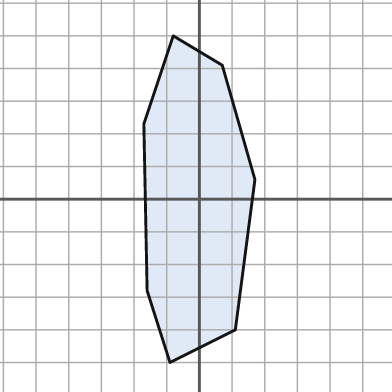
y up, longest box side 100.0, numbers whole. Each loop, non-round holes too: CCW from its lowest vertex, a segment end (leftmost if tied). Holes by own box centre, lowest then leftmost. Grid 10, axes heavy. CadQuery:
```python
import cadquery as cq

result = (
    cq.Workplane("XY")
    .moveTo(-9.0, -50.0)
    .lineTo(11.0, -40.0)
    .lineTo(17.0, 6.0)
    .lineTo(7.0, 41.0)
    .lineTo(-8.0, 50.0)
    .lineTo(-17.0, 23.0)
    .lineTo(-16.0, -28.0)
    .close()
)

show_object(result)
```